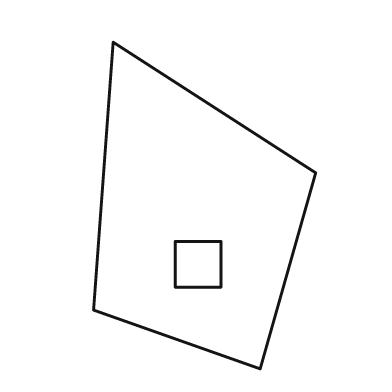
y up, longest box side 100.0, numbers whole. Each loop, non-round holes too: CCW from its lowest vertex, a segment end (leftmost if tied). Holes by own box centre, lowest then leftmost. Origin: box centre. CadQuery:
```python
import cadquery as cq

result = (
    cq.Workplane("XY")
    .moveTo(17.0, -50.0)
    .lineTo(34.0, 10.0)
    .lineTo(-28.0, 50.0)
    .lineTo(-34.0, -32.0)
    .close()
    .moveTo(-9.0, -25.0)
    .lineTo(5.0, -25.0)
    .lineTo(5.0, -11.0)
    .lineTo(-9.0, -11.0)
    .close()
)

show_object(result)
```